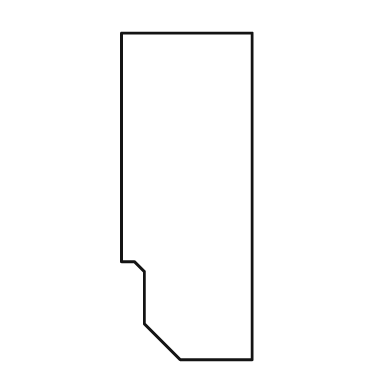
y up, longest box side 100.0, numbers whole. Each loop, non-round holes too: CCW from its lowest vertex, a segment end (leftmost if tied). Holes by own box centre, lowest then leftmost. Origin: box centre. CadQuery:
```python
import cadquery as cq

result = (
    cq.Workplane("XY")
    .moveTo(-2.0, -50.0)
    .lineTo(20.0, -50.0)
    .lineTo(20.0, 50.0)
    .lineTo(-20.0, 50.0)
    .lineTo(-20.0, -20.0)
    .lineTo(-16.0, -20.0)
    .lineTo(-13.0, -23.0)
    .lineTo(-13.0, -39.0)
    .close()
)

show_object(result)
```